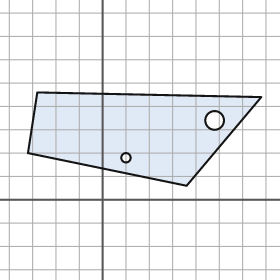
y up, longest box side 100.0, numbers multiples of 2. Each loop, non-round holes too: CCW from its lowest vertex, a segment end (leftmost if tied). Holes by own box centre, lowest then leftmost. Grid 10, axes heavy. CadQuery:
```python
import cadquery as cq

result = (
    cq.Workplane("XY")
    .moveTo(36.0, 6.0)
    .lineTo(68.0, 44.0)
    .lineTo(-28.0, 46.0)
    .lineTo(-32.0, 20.0)
    .close()
    .moveTo(10.0, 18.0)
    .circle(2.0)
    .moveTo(48.0, 34.0)
    .circle(4.0)
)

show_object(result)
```